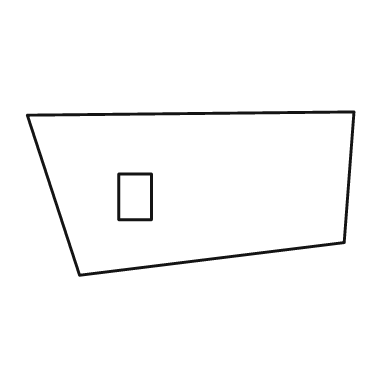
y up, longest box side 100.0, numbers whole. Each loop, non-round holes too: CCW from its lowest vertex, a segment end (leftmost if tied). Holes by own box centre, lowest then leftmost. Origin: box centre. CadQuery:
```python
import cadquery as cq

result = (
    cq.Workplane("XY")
    .moveTo(-34.0, -25.0)
    .lineTo(47.0, -15.0)
    .lineTo(50.0, 25.0)
    .lineTo(-50.0, 24.0)
    .close()
    .moveTo(-22.0, -8.0)
    .lineTo(-12.0, -8.0)
    .lineTo(-12.0, 6.0)
    .lineTo(-22.0, 6.0)
    .close()
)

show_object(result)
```